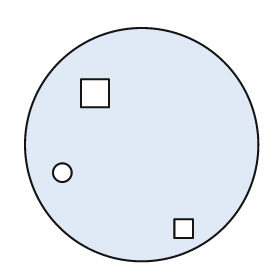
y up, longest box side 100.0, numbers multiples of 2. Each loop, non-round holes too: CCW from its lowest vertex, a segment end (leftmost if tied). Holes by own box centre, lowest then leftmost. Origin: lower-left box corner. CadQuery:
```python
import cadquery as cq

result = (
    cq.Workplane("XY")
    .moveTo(50.0, 50.0)
    .circle(50.0)
    .moveTo(64.0, 10.0)
    .lineTo(72.0, 10.0)
    .lineTo(72.0, 18.0)
    .lineTo(64.0, 18.0)
    .close()
    .moveTo(16.0, 38.0)
    .circle(4.0)
    .moveTo(24.0, 66.0)
    .lineTo(36.0, 66.0)
    .lineTo(36.0, 78.0)
    .lineTo(24.0, 78.0)
    .close()
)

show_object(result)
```